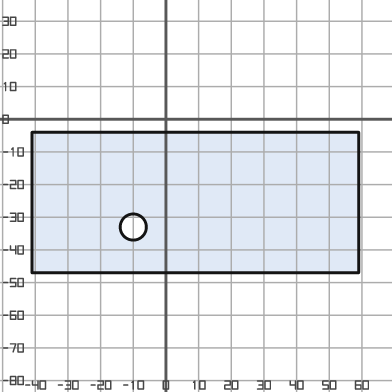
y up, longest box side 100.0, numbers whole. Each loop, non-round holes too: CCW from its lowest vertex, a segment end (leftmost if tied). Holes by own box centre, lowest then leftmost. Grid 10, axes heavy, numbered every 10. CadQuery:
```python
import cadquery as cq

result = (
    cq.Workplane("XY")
    .moveTo(-41.0, -47.0)
    .lineTo(59.0, -47.0)
    .lineTo(59.0, -4.0)
    .lineTo(-41.0, -4.0)
    .close()
    .moveTo(-10.0, -33.0)
    .circle(4.0)
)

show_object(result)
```